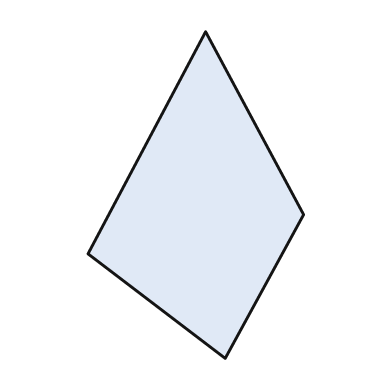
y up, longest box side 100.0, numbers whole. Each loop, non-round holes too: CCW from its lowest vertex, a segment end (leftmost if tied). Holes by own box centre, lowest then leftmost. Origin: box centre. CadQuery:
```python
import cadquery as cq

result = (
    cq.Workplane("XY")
    .moveTo(9.0, -50.0)
    .lineTo(33.0, -6.0)
    .lineTo(3.0, 50.0)
    .lineTo(-33.0, -18.0)
    .close()
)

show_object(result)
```